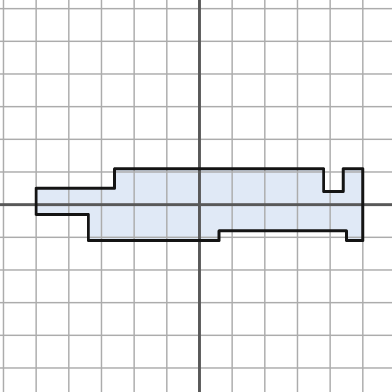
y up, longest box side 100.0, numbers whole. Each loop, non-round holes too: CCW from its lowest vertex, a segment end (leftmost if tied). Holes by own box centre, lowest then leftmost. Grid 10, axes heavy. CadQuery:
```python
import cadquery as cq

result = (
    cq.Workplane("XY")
    .moveTo(-34.0, -11.0)
    .lineTo(6.0, -11.0)
    .lineTo(6.0, -8.0)
    .lineTo(45.0, -8.0)
    .lineTo(45.0, -11.0)
    .lineTo(50.0, -11.0)
    .lineTo(50.0, 11.0)
    .lineTo(44.0, 11.0)
    .lineTo(44.0, 4.0)
    .lineTo(38.0, 4.0)
    .lineTo(38.0, 11.0)
    .lineTo(-26.0, 11.0)
    .lineTo(-26.0, 5.0)
    .lineTo(-50.0, 5.0)
    .lineTo(-50.0, -3.0)
    .lineTo(-34.0, -3.0)
    .close()
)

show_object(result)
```